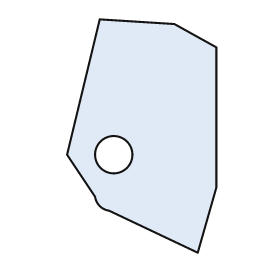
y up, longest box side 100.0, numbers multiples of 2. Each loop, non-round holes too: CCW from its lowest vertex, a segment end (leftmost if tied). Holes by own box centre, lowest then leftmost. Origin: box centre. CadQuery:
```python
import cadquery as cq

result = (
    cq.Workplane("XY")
    .moveTo(24.0, -50.0)
    .lineTo(32.0, -22.0)
    .lineTo(32.0, 38.0)
    .lineTo(14.0, 48.0)
    .lineTo(-18.0, 50.0)
    .lineTo(-32.0, -8.0)
    .lineTo(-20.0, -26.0)
    .threePointArc((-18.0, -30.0), (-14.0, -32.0))
    .close()
    .moveTo(-12.0, -8.0)
    .circle(8.0)
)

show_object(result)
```